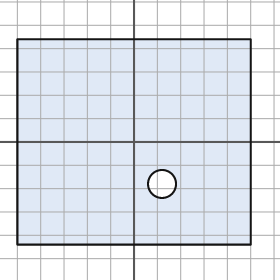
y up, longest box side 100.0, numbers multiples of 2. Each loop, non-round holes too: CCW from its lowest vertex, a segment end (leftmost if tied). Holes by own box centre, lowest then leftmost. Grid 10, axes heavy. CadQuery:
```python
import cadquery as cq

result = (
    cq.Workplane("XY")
    .moveTo(-50.0, -44.0)
    .lineTo(50.0, -44.0)
    .lineTo(50.0, 44.0)
    .lineTo(-50.0, 44.0)
    .close()
    .moveTo(12.0, -18.0)
    .circle(6.0)
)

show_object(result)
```